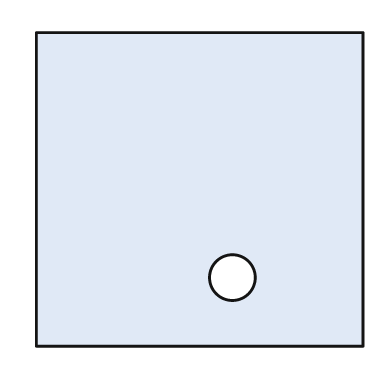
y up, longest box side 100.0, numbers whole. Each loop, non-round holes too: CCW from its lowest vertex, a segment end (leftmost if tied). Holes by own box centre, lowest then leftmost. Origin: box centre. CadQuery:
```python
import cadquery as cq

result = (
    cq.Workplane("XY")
    .moveTo(-50.0, -48.0)
    .lineTo(50.0, -48.0)
    .lineTo(50.0, 48.0)
    .lineTo(-50.0, 48.0)
    .close()
    .moveTo(10.0, -27.0)
    .circle(7.0)
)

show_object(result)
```